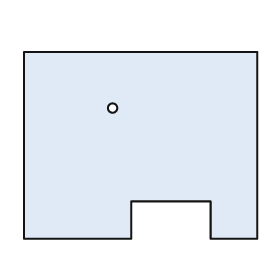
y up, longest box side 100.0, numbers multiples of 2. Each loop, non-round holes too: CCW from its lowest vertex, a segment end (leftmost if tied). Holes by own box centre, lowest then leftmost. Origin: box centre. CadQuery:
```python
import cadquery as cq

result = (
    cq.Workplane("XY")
    .moveTo(-50.0, -40.0)
    .lineTo(-4.0, -40.0)
    .lineTo(-4.0, -24.0)
    .lineTo(30.0, -24.0)
    .lineTo(30.0, -40.0)
    .lineTo(50.0, -40.0)
    .lineTo(50.0, 40.0)
    .lineTo(-50.0, 40.0)
    .close()
    .moveTo(-12.0, 16.0)
    .circle(2.0)
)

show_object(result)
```